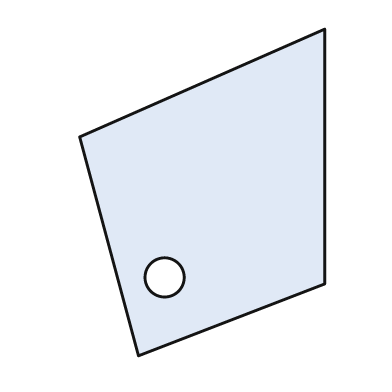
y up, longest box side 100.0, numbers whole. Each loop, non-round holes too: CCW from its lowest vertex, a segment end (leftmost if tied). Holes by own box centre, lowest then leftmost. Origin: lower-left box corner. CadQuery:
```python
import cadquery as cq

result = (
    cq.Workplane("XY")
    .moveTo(18.0, 0.0)
    .lineTo(75.0, 22.0)
    .lineTo(75.0, 100.0)
    .lineTo(0.0, 67.0)
    .close()
    .moveTo(26.0, 24.0)
    .circle(6.0)
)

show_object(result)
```